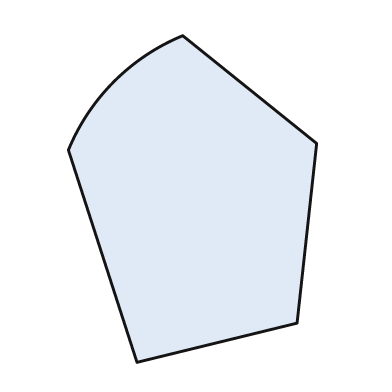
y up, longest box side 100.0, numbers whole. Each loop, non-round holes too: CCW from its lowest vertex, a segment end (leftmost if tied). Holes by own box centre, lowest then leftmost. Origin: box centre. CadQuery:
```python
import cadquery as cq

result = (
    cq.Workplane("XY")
    .moveTo(-17.0, -50.0)
    .lineTo(32.0, -38.0)
    .lineTo(38.0, 17.0)
    .lineTo(-3.0, 50.0)
    .threePointArc((-24.0, 36.0), (-38.0, 15.0))
    .close()
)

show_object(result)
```